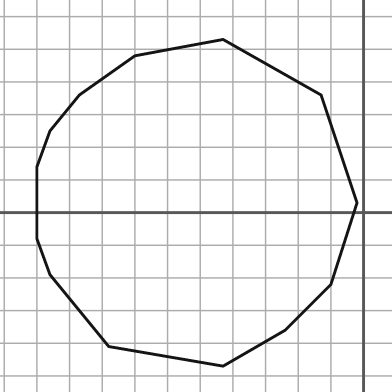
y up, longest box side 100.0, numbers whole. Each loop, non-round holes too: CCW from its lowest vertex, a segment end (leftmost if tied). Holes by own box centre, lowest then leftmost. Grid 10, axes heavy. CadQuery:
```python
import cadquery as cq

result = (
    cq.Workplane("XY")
    .moveTo(-43.0, -47.0)
    .lineTo(-24.0, -36.0)
    .lineTo(-10.0, -22.0)
    .lineTo(-2.0, 3.0)
    .lineTo(-13.0, 36.0)
    .lineTo(-43.0, 53.0)
    .lineTo(-70.0, 48.0)
    .lineTo(-87.0, 36.0)
    .lineTo(-96.0, 25.0)
    .lineTo(-100.0, 14.0)
    .lineTo(-100.0, -8.0)
    .lineTo(-96.0, -19.0)
    .lineTo(-78.0, -41.0)
    .close()
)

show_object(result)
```